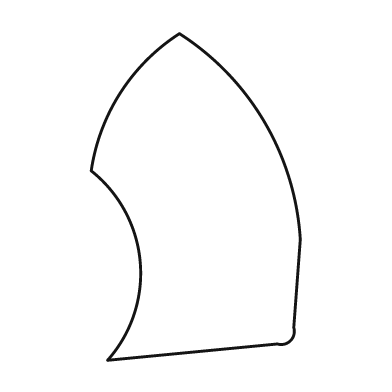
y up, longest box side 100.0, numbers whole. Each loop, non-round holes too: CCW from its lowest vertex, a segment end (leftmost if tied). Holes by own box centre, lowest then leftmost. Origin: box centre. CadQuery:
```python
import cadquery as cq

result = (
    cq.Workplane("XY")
    .moveTo(-27.0, -50.0)
    .lineTo(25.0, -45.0)
    .threePointArc((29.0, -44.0), (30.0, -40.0))
    .lineTo(32.0, -13.0)
    .threePointArc((21.0, 23.0), (-5.0, 50.0))
    .threePointArc((-23.0, 32.0), (-32.0, 8.0))
    .threePointArc((-17.0, -20.0), (-27.0, -50.0))
    .close()
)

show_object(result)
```